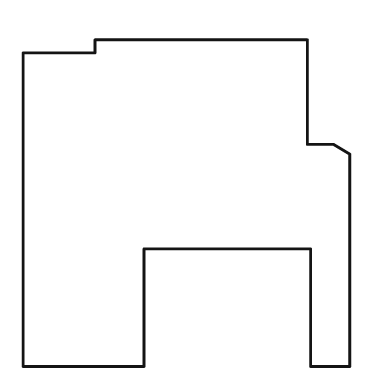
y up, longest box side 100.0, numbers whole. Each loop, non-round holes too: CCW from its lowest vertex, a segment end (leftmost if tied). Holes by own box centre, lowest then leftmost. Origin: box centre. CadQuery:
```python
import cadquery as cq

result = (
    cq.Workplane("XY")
    .moveTo(-50.0, -50.0)
    .lineTo(-13.0, -50.0)
    .lineTo(-13.0, -14.0)
    .lineTo(38.0, -14.0)
    .lineTo(38.0, -50.0)
    .lineTo(50.0, -50.0)
    .lineTo(50.0, 15.0)
    .lineTo(45.0, 18.0)
    .lineTo(37.0, 18.0)
    .lineTo(37.0, 50.0)
    .lineTo(-28.0, 50.0)
    .lineTo(-28.0, 46.0)
    .lineTo(-50.0, 46.0)
    .close()
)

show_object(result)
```